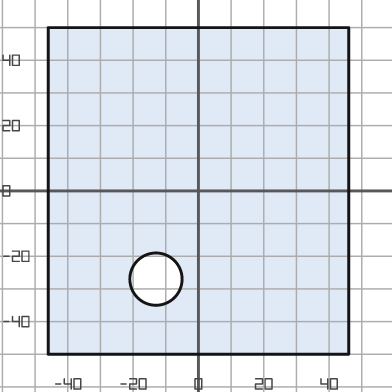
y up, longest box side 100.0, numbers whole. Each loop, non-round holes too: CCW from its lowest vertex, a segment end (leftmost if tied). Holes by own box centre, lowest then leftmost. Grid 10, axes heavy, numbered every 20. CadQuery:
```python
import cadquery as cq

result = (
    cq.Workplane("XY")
    .moveTo(-46.0, -50.0)
    .lineTo(46.0, -50.0)
    .lineTo(46.0, 50.0)
    .lineTo(-46.0, 50.0)
    .close()
    .moveTo(-13.0, -27.0)
    .circle(8.0)
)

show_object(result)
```